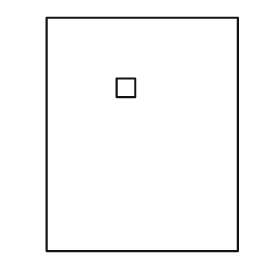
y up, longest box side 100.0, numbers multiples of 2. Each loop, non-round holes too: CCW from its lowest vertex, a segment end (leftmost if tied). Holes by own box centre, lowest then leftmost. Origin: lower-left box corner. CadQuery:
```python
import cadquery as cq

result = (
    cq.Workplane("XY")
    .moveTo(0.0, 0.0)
    .lineTo(82.0, 0.0)
    .lineTo(82.0, 100.0)
    .lineTo(0.0, 100.0)
    .close()
    .moveTo(30.0, 66.0)
    .lineTo(38.0, 66.0)
    .lineTo(38.0, 74.0)
    .lineTo(30.0, 74.0)
    .close()
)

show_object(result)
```